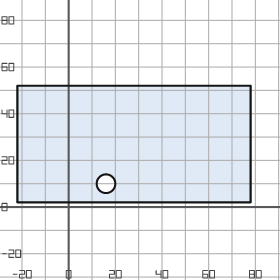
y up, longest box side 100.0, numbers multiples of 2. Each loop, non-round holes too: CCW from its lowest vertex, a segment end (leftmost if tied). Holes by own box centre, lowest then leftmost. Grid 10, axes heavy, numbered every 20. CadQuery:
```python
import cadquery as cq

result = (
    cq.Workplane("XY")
    .moveTo(-22.0, 2.0)
    .lineTo(78.0, 2.0)
    .lineTo(78.0, 52.0)
    .lineTo(-22.0, 52.0)
    .close()
    .moveTo(16.0, 10.0)
    .circle(4.0)
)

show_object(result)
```